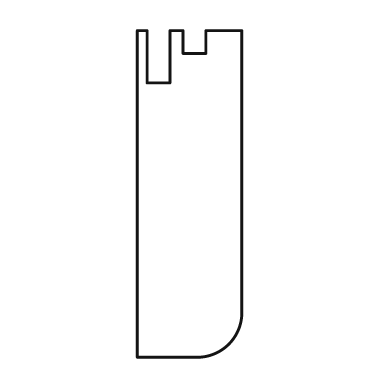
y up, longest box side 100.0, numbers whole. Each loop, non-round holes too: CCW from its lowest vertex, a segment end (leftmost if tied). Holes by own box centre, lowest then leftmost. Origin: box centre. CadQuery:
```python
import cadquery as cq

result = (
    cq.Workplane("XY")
    .moveTo(-16.0, -50.0)
    .lineTo(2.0, -50.0)
    .threePointArc((12.0, -46.0), (16.0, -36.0))
    .lineTo(16.0, 50.0)
    .lineTo(5.0, 50.0)
    .lineTo(5.0, 43.0)
    .lineTo(-2.0, 43.0)
    .lineTo(-2.0, 50.0)
    .lineTo(-6.0, 50.0)
    .lineTo(-6.0, 34.0)
    .lineTo(-13.0, 34.0)
    .lineTo(-13.0, 50.0)
    .lineTo(-16.0, 50.0)
    .close()
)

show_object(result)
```